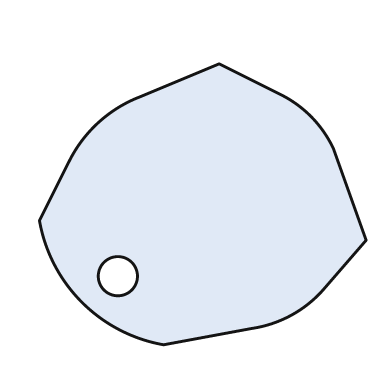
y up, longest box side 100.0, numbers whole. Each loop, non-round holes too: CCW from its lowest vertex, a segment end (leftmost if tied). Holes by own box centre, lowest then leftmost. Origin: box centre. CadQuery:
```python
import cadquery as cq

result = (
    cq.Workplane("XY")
    .moveTo(-12.0, -43.0)
    .lineTo(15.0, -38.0)
    .threePointArc((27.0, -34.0), (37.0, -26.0))
    .lineTo(50.0, -11.0)
    .lineTo(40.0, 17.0)
    .threePointArc((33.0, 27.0), (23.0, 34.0))
    .lineTo(5.0, 43.0)
    .lineTo(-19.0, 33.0)
    .threePointArc((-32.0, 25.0), (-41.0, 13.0))
    .lineTo(-50.0, -5.0)
    .threePointArc((-37.0, -30.0), (-12.0, -43.0))
    .close()
    .moveTo(-26.0, -22.0)
    .circle(6.0)
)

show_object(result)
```